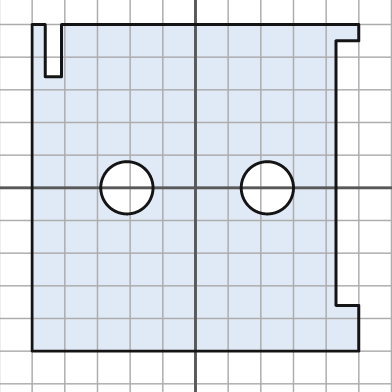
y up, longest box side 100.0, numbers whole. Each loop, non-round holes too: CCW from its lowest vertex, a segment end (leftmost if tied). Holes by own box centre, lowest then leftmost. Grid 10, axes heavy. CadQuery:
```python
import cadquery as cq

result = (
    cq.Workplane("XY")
    .moveTo(-50.0, -50.0)
    .lineTo(50.0, -50.0)
    .lineTo(50.0, -36.0)
    .lineTo(43.0, -36.0)
    .lineTo(43.0, 45.0)
    .lineTo(50.0, 45.0)
    .lineTo(50.0, 50.0)
    .lineTo(-41.0, 50.0)
    .lineTo(-41.0, 34.0)
    .lineTo(-46.0, 34.0)
    .lineTo(-46.0, 50.0)
    .lineTo(-50.0, 50.0)
    .close()
    .moveTo(-21.0, 0.0)
    .circle(8.0)
    .moveTo(22.0, 0.0)
    .circle(8.0)
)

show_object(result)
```